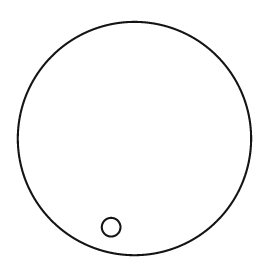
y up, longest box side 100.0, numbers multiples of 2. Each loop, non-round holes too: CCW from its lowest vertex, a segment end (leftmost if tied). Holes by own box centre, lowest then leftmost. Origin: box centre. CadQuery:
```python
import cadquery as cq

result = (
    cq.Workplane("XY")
    .moveTo(0.0, 0.0)
    .circle(50.0)
    .moveTo(-10.0, -38.0)
    .circle(4.0)
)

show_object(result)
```